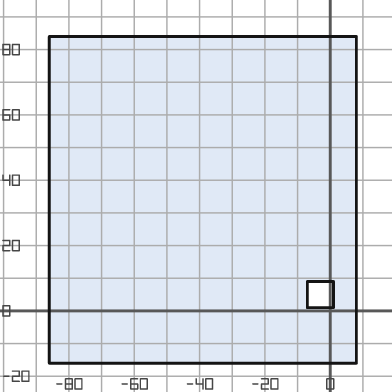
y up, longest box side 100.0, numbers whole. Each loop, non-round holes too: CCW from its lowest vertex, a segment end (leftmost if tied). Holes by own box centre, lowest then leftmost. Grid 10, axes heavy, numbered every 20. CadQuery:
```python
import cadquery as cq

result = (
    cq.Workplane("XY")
    .moveTo(-86.0, -16.0)
    .lineTo(8.0, -16.0)
    .lineTo(8.0, 84.0)
    .lineTo(-86.0, 84.0)
    .close()
    .moveTo(-7.0, 1.0)
    .lineTo(1.0, 1.0)
    .lineTo(1.0, 9.0)
    .lineTo(-7.0, 9.0)
    .close()
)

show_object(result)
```